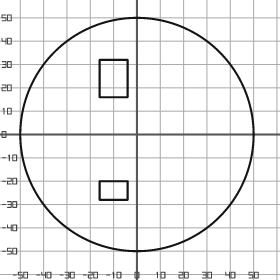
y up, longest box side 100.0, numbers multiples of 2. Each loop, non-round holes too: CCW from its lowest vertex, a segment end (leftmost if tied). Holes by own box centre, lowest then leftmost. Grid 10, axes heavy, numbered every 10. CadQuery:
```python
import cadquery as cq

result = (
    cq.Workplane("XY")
    .moveTo(0.0, 0.0)
    .circle(50.0)
    .moveTo(-16.0, -28.0)
    .lineTo(-4.0, -28.0)
    .lineTo(-4.0, -20.0)
    .lineTo(-16.0, -20.0)
    .close()
    .moveTo(-16.0, 16.0)
    .lineTo(-4.0, 16.0)
    .lineTo(-4.0, 32.0)
    .lineTo(-16.0, 32.0)
    .close()
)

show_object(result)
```